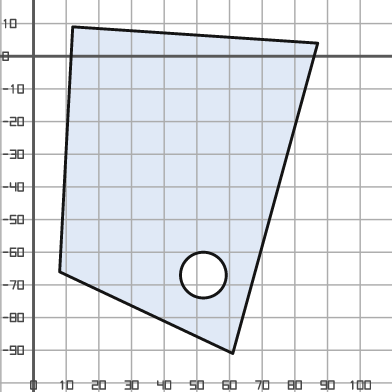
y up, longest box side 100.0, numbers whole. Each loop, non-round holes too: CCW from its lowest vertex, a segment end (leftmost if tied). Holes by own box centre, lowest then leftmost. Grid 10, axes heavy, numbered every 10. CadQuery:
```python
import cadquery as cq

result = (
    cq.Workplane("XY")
    .moveTo(61.0, -91.0)
    .lineTo(87.0, 4.0)
    .lineTo(12.0, 9.0)
    .lineTo(8.0, -66.0)
    .close()
    .moveTo(52.0, -67.0)
    .circle(7.0)
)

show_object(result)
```